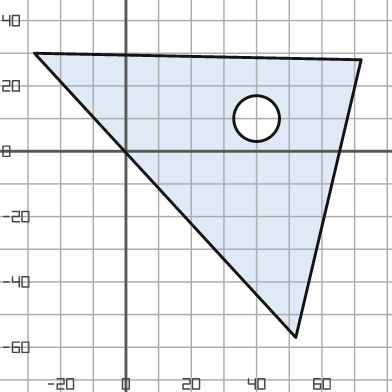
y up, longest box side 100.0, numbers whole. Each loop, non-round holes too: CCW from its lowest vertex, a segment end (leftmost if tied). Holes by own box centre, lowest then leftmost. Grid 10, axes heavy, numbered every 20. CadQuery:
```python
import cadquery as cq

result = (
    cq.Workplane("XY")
    .moveTo(52.0, -57.0)
    .lineTo(72.0, 28.0)
    .lineTo(-28.0, 30.0)
    .close()
    .moveTo(40.0, 10.0)
    .circle(7.0)
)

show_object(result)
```